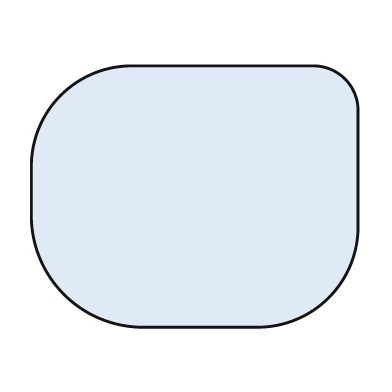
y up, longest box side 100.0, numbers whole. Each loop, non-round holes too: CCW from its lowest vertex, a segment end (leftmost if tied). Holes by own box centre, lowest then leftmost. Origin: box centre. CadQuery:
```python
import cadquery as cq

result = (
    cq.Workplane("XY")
    .moveTo(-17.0, -40.0)
    .lineTo(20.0, -40.0)
    .threePointArc((41.0, -31.0), (50.0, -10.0))
    .lineTo(50.0, 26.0)
    .threePointArc((46.0, 36.0), (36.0, 40.0))
    .lineTo(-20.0, 40.0)
    .threePointArc((-41.0, 31.0), (-50.0, 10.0))
    .lineTo(-50.0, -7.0)
    .threePointArc((-40.0, -30.0), (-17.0, -40.0))
    .close()
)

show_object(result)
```